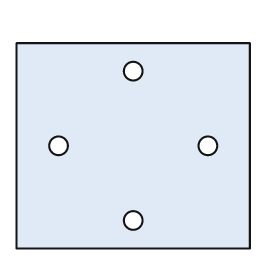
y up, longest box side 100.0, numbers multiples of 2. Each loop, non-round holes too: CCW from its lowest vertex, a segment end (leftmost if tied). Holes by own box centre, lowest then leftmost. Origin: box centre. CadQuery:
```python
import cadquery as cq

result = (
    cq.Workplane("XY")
    .moveTo(-50.0, -44.0)
    .lineTo(50.0, -44.0)
    .lineTo(50.0, 44.0)
    .lineTo(-50.0, 44.0)
    .close()
    .moveTo(0.0, -32.0)
    .circle(4.0)
    .moveTo(-32.0, 0.0)
    .circle(4.0)
    .moveTo(32.0, 0.0)
    .circle(4.0)
    .moveTo(0.0, 32.0)
    .circle(4.0)
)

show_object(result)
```